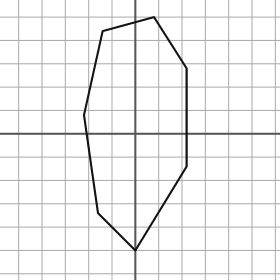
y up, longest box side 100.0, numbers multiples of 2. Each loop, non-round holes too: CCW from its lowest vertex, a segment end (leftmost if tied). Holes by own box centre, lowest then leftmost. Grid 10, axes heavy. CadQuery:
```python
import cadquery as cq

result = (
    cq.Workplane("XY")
    .moveTo(0.0, -50.0)
    .lineTo(22.0, -14.0)
    .lineTo(22.0, 28.0)
    .lineTo(8.0, 50.0)
    .lineTo(-14.0, 44.0)
    .lineTo(-22.0, 8.0)
    .lineTo(-16.0, -34.0)
    .close()
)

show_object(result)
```